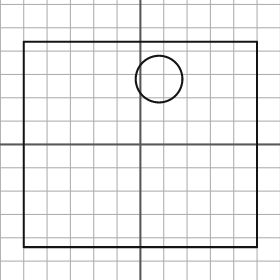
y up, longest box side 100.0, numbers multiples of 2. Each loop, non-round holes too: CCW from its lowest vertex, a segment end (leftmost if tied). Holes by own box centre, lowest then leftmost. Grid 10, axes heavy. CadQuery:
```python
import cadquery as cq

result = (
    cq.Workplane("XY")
    .moveTo(-50.0, -44.0)
    .lineTo(50.0, -44.0)
    .lineTo(50.0, 44.0)
    .lineTo(-50.0, 44.0)
    .close()
    .moveTo(8.0, 28.0)
    .circle(10.0)
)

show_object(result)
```